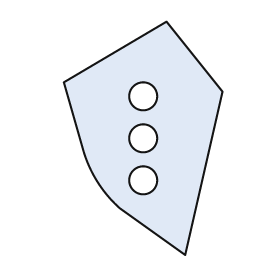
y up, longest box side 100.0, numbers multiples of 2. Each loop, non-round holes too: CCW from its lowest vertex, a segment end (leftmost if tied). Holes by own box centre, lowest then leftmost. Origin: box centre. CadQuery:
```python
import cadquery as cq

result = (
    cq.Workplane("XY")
    .moveTo(18.0, -50.0)
    .lineTo(34.0, 20.0)
    .lineTo(10.0, 50.0)
    .lineTo(-34.0, 24.0)
    .lineTo(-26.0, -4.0)
    .threePointArc((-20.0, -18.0), (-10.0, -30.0))
    .close()
    .moveTo(0.0, -18.0)
    .circle(6.0)
    .moveTo(0.0, 0.0)
    .circle(6.0)
    .moveTo(0.0, 18.0)
    .circle(6.0)
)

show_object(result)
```